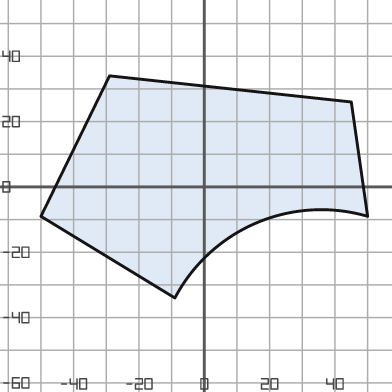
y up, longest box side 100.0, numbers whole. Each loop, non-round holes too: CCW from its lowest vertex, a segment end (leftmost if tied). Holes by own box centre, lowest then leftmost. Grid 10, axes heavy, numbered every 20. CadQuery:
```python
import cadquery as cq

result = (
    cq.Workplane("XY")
    .moveTo(-9.0, -34.0)
    .threePointArc((16.0, -11.0), (50.0, -9.0))
    .lineTo(45.0, 26.0)
    .lineTo(-29.0, 34.0)
    .lineTo(-50.0, -9.0)
    .close()
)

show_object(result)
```